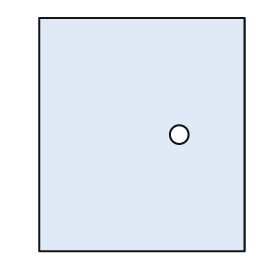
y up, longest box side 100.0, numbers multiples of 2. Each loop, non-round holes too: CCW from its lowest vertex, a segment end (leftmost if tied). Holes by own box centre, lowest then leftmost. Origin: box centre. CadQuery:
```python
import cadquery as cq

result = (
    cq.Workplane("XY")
    .moveTo(-44.0, -50.0)
    .lineTo(44.0, -50.0)
    .lineTo(44.0, 50.0)
    .lineTo(-44.0, 50.0)
    .close()
    .moveTo(16.0, 0.0)
    .circle(4.0)
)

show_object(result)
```